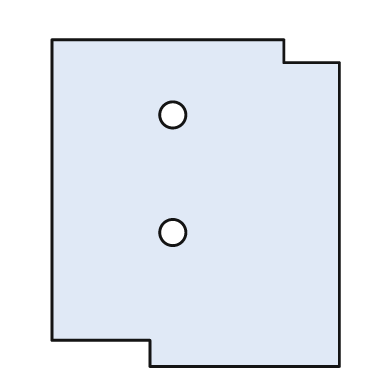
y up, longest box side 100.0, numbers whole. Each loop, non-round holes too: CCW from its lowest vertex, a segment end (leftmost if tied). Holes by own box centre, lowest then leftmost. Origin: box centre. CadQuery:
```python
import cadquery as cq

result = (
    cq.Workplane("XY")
    .moveTo(-14.0, -50.0)
    .lineTo(44.0, -50.0)
    .lineTo(44.0, 43.0)
    .lineTo(27.0, 43.0)
    .lineTo(27.0, 50.0)
    .lineTo(-44.0, 50.0)
    .lineTo(-44.0, -42.0)
    .lineTo(-14.0, -42.0)
    .close()
    .moveTo(-7.0, -9.0)
    .circle(4.0)
    .moveTo(-7.0, 27.0)
    .circle(4.0)
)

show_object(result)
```